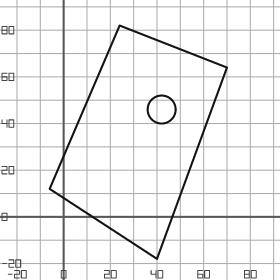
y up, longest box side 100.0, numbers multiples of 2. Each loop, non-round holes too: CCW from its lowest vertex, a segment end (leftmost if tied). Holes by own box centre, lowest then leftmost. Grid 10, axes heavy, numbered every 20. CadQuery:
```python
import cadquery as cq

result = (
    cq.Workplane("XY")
    .moveTo(40.0, -18.0)
    .lineTo(70.0, 64.0)
    .lineTo(24.0, 82.0)
    .lineTo(-6.0, 12.0)
    .close()
    .moveTo(42.0, 46.0)
    .circle(6.0)
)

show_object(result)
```